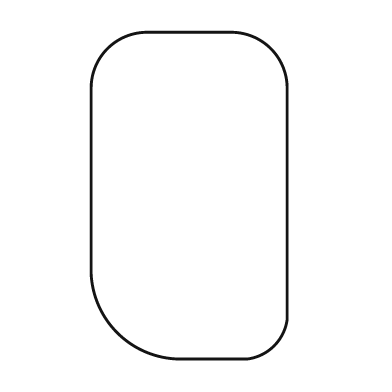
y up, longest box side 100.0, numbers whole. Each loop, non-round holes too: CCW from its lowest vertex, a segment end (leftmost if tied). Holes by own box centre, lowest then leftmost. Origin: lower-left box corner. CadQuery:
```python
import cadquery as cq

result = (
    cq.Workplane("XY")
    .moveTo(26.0, 0.0)
    .lineTo(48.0, 0.0)
    .threePointArc((56.0, 4.0), (60.0, 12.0))
    .lineTo(60.0, 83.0)
    .threePointArc((55.0, 95.0), (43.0, 100.0))
    .lineTo(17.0, 100.0)
    .threePointArc((5.0, 95.0), (0.0, 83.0))
    .lineTo(0.0, 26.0)
    .threePointArc((8.0, 8.0), (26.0, 0.0))
    .close()
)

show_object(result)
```